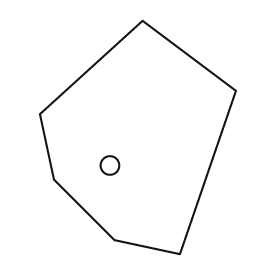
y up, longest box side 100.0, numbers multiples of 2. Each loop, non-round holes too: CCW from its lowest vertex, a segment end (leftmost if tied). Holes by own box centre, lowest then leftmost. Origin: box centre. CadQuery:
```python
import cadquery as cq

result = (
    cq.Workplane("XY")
    .moveTo(18.0, -50.0)
    .lineTo(42.0, 20.0)
    .lineTo(2.0, 50.0)
    .lineTo(-42.0, 10.0)
    .lineTo(-36.0, -18.0)
    .lineTo(-10.0, -44.0)
    .close()
    .moveTo(-12.0, -12.0)
    .circle(4.0)
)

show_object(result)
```